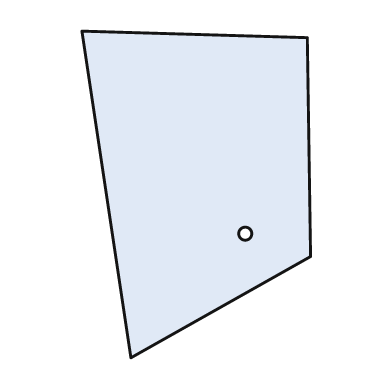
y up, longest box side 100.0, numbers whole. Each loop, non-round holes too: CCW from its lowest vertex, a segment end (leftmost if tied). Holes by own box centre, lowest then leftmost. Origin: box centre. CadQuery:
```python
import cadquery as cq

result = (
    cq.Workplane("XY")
    .moveTo(-20.0, -50.0)
    .lineTo(35.0, -19.0)
    .lineTo(34.0, 48.0)
    .lineTo(-35.0, 50.0)
    .close()
    .moveTo(15.0, -12.0)
    .circle(2.0)
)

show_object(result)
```